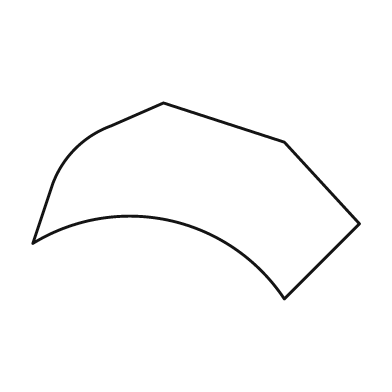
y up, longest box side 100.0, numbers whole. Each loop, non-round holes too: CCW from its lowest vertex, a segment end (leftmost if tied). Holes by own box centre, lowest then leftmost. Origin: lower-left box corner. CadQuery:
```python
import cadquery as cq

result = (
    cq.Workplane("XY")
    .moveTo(77.0, 0.0)
    .lineTo(100.0, 23.0)
    .lineTo(77.0, 48.0)
    .lineTo(40.0, 60.0)
    .lineTo(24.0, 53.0)
    .threePointArc((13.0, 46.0), (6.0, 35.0))
    .lineTo(0.0, 17.0)
    .threePointArc((42.0, 24.0), (77.0, 0.0))
    .close()
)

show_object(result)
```